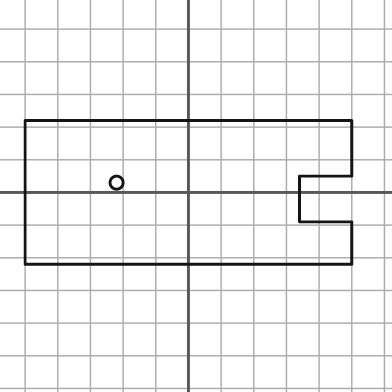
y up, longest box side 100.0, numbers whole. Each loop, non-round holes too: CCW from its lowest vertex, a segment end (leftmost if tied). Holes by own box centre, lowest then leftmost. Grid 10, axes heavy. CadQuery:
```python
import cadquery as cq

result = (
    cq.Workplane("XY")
    .moveTo(-50.0, -22.0)
    .lineTo(50.0, -22.0)
    .lineTo(50.0, -9.0)
    .lineTo(34.0, -9.0)
    .lineTo(34.0, 5.0)
    .lineTo(50.0, 5.0)
    .lineTo(50.0, 22.0)
    .lineTo(-50.0, 22.0)
    .close()
    .moveTo(-22.0, 3.0)
    .circle(2.0)
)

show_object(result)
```